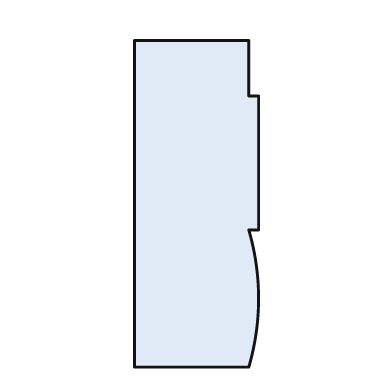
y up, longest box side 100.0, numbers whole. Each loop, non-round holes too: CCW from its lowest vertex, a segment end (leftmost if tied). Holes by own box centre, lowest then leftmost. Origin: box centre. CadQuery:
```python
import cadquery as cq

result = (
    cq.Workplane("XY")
    .moveTo(-19.0, -50.0)
    .lineTo(16.0, -50.0)
    .threePointArc((19.0, -29.0), (16.0, -8.0))
    .lineTo(19.0, -8.0)
    .lineTo(19.0, 33.0)
    .lineTo(16.0, 33.0)
    .lineTo(16.0, 50.0)
    .lineTo(-19.0, 50.0)
    .close()
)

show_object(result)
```